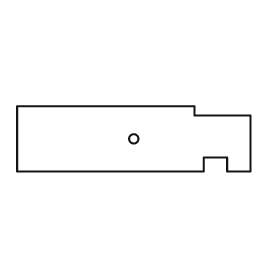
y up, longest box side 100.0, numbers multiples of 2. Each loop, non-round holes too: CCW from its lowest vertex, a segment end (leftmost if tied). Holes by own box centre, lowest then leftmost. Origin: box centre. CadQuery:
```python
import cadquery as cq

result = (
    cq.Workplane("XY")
    .moveTo(-50.0, -14.0)
    .lineTo(30.0, -14.0)
    .lineTo(30.0, -8.0)
    .lineTo(40.0, -8.0)
    .lineTo(40.0, -14.0)
    .lineTo(50.0, -14.0)
    .lineTo(50.0, 10.0)
    .lineTo(26.0, 10.0)
    .lineTo(26.0, 14.0)
    .lineTo(-50.0, 14.0)
    .close()
    .moveTo(0.0, 0.0)
    .circle(2.0)
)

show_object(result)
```